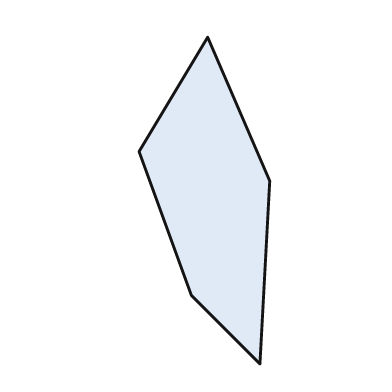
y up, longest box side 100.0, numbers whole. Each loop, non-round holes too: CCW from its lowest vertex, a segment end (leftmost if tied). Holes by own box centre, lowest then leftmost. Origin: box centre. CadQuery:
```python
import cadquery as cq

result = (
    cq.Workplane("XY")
    .moveTo(17.0, -50.0)
    .lineTo(20.0, 6.0)
    .lineTo(1.0, 50.0)
    .lineTo(-20.0, 15.0)
    .lineTo(-4.0, -29.0)
    .close()
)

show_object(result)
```